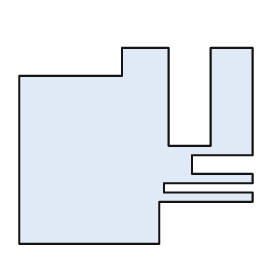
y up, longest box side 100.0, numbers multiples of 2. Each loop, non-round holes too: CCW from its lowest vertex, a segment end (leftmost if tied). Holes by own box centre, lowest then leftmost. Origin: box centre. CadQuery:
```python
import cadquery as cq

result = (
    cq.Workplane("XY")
    .moveTo(-50.0, -42.0)
    .lineTo(10.0, -42.0)
    .lineTo(10.0, -24.0)
    .lineTo(50.0, -24.0)
    .lineTo(50.0, -20.0)
    .lineTo(12.0, -20.0)
    .lineTo(12.0, -16.0)
    .lineTo(50.0, -16.0)
    .lineTo(50.0, -12.0)
    .lineTo(24.0, -12.0)
    .lineTo(24.0, -4.0)
    .lineTo(50.0, -4.0)
    .lineTo(50.0, 42.0)
    .lineTo(32.0, 42.0)
    .lineTo(32.0, 0.0)
    .lineTo(14.0, 0.0)
    .lineTo(14.0, 42.0)
    .lineTo(-6.0, 42.0)
    .lineTo(-6.0, 30.0)
    .lineTo(-50.0, 30.0)
    .close()
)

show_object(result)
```